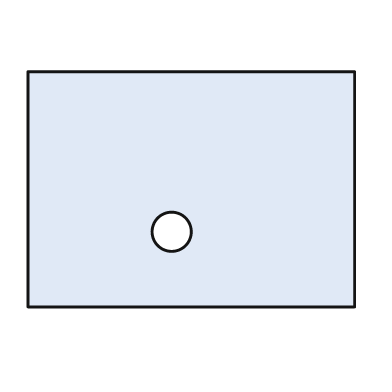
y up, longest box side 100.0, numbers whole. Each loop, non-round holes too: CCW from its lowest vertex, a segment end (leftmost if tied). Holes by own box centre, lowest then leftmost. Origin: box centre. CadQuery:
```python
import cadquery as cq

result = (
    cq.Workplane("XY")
    .moveTo(-50.0, -36.0)
    .lineTo(50.0, -36.0)
    .lineTo(50.0, 36.0)
    .lineTo(-50.0, 36.0)
    .close()
    .moveTo(-6.0, -13.0)
    .circle(6.0)
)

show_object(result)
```